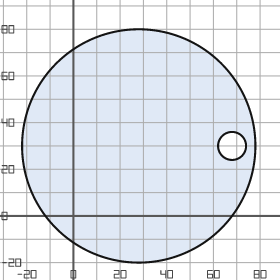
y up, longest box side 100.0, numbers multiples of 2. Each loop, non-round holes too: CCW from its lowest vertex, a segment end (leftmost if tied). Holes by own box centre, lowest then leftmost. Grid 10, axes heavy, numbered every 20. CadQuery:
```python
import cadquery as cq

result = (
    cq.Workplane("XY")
    .moveTo(28.0, 30.0)
    .circle(50.0)
    .moveTo(68.0, 30.0)
    .circle(6.0)
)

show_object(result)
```